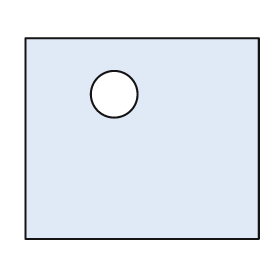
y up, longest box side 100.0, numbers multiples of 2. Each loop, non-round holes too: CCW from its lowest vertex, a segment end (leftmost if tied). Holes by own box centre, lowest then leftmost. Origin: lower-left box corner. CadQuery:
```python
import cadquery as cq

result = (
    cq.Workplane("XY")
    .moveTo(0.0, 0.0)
    .lineTo(100.0, 0.0)
    .lineTo(100.0, 86.0)
    .lineTo(0.0, 86.0)
    .close()
    .moveTo(38.0, 62.0)
    .circle(10.0)
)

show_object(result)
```